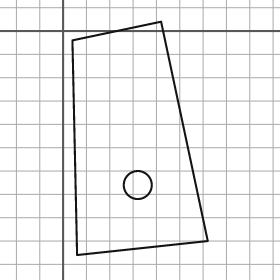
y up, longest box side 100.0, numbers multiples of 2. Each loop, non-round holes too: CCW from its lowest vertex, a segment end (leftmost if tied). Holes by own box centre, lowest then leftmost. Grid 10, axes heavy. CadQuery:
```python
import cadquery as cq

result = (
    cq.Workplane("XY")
    .moveTo(6.0, -96.0)
    .lineTo(62.0, -90.0)
    .lineTo(42.0, 4.0)
    .lineTo(4.0, -4.0)
    .close()
    .moveTo(32.0, -66.0)
    .circle(6.0)
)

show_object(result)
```